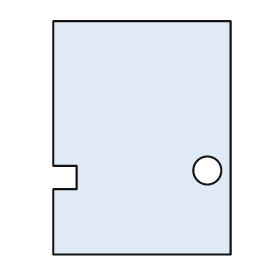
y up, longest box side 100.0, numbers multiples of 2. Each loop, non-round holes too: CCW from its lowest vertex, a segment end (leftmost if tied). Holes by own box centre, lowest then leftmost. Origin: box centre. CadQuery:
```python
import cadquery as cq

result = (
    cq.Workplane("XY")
    .moveTo(-38.0, -50.0)
    .lineTo(38.0, -50.0)
    .lineTo(38.0, 50.0)
    .lineTo(-38.0, 50.0)
    .lineTo(-38.0, -12.0)
    .lineTo(-28.0, -12.0)
    .lineTo(-28.0, -22.0)
    .lineTo(-38.0, -22.0)
    .close()
    .moveTo(28.0, -14.0)
    .circle(6.0)
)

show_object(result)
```